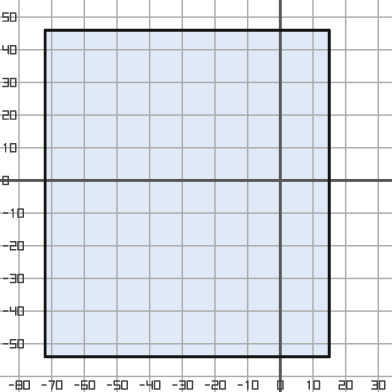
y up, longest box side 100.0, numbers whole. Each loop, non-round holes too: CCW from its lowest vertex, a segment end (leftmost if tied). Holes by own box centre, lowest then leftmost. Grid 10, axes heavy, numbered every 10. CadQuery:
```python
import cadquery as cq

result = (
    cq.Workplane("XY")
    .moveTo(-72.0, -54.0)
    .lineTo(15.0, -54.0)
    .lineTo(15.0, 46.0)
    .lineTo(-72.0, 46.0)
    .close()
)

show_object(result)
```